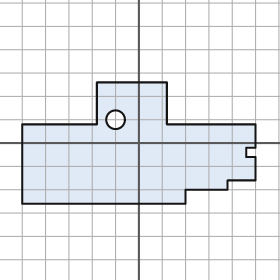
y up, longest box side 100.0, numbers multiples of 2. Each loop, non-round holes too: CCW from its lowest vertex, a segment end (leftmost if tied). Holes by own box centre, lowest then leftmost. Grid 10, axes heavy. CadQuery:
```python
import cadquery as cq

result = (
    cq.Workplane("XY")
    .moveTo(-50.0, -26.0)
    .lineTo(20.0, -26.0)
    .lineTo(20.0, -20.0)
    .lineTo(38.0, -20.0)
    .lineTo(38.0, -16.0)
    .lineTo(50.0, -16.0)
    .lineTo(50.0, -6.0)
    .lineTo(46.0, -6.0)
    .lineTo(46.0, -2.0)
    .lineTo(50.0, -2.0)
    .lineTo(50.0, 8.0)
    .lineTo(12.0, 8.0)
    .lineTo(12.0, 26.0)
    .lineTo(-18.0, 26.0)
    .lineTo(-18.0, 8.0)
    .lineTo(-50.0, 8.0)
    .close()
    .moveTo(-10.0, 10.0)
    .circle(4.0)
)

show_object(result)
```